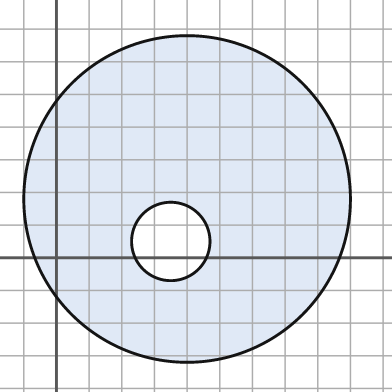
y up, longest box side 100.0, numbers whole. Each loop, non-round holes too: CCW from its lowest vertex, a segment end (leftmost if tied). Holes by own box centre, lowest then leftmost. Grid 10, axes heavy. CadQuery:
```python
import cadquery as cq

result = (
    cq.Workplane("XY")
    .moveTo(40.0, 18.0)
    .circle(50.0)
    .moveTo(35.0, 5.0)
    .circle(12.0)
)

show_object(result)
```